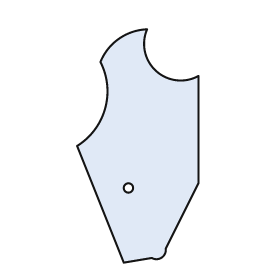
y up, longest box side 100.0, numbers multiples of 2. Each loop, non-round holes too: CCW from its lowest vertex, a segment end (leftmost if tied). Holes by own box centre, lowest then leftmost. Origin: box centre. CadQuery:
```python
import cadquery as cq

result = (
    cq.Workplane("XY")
    .moveTo(-6.0, -50.0)
    .lineTo(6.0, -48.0)
    .threePointArc((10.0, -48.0), (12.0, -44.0))
    .lineTo(26.0, -16.0)
    .lineTo(26.0, 30.0)
    .threePointArc((8.0, 32.0), (4.0, 50.0))
    .threePointArc((-8.0, 46.0), (-16.0, 36.0))
    .threePointArc((-14.0, 16.0), (-26.0, 0.0))
    .close()
    .moveTo(-4.0, -18.0)
    .circle(2.0)
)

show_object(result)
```